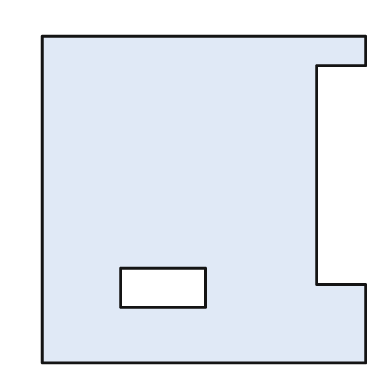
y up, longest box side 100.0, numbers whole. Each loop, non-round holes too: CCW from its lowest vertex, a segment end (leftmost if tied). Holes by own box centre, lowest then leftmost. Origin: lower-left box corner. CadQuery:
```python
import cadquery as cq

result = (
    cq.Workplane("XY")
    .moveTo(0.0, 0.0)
    .lineTo(99.0, 0.0)
    .lineTo(99.0, 24.0)
    .lineTo(84.0, 24.0)
    .lineTo(84.0, 91.0)
    .lineTo(99.0, 91.0)
    .lineTo(99.0, 100.0)
    .lineTo(0.0, 100.0)
    .close()
    .moveTo(24.0, 17.0)
    .lineTo(50.0, 17.0)
    .lineTo(50.0, 29.0)
    .lineTo(24.0, 29.0)
    .close()
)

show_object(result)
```